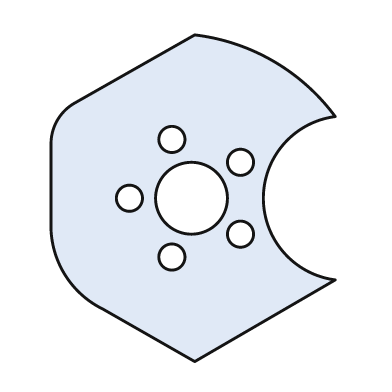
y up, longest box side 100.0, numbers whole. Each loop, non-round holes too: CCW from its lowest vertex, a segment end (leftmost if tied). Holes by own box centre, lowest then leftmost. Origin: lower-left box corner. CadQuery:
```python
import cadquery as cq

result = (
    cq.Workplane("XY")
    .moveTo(44.0, 0.0)
    .lineTo(87.0, 25.0)
    .threePointArc((65.0, 50.0), (87.0, 75.0))
    .threePointArc((68.0, 92.0), (44.0, 100.0))
    .lineTo(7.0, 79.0)
    .threePointArc((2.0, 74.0), (0.0, 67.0))
    .lineTo(0.0, 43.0)
    .threePointArc((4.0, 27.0), (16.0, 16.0))
    .close()
    .moveTo(37.0, 32.0)
    .circle(4.0)
    .moveTo(58.0, 39.0)
    .circle(4.0)
    .moveTo(24.0, 50.0)
    .circle(4.0)
    .moveTo(43.0, 50.0)
    .circle(11.0)
    .moveTo(58.0, 61.0)
    .circle(4.0)
    .moveTo(37.0, 68.0)
    .circle(4.0)
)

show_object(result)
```